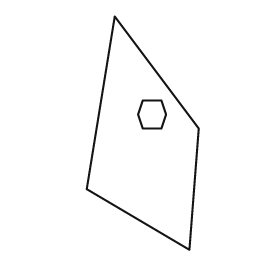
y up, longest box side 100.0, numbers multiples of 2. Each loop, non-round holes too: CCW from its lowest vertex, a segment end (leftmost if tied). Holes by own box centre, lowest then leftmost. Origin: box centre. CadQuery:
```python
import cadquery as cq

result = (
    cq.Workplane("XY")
    .moveTo(20.0, -50.0)
    .lineTo(24.0, 2.0)
    .lineTo(-12.0, 50.0)
    .lineTo(-24.0, -24.0)
    .close()
    .moveTo(0.0, 2.0)
    .lineTo(8.0, 2.0)
    .lineTo(10.0, 8.0)
    .lineTo(8.0, 14.0)
    .lineTo(0.0, 14.0)
    .lineTo(-2.0, 8.0)
    .close()
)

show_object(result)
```